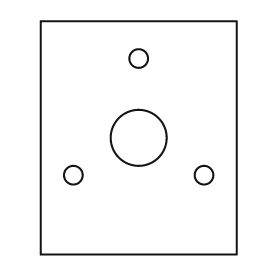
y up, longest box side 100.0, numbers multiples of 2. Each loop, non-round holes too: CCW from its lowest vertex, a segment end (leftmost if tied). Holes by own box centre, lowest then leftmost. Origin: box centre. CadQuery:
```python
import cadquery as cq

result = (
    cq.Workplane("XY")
    .moveTo(-42.0, -50.0)
    .lineTo(42.0, -50.0)
    .lineTo(42.0, 50.0)
    .lineTo(-42.0, 50.0)
    .close()
    .moveTo(-28.0, -16.0)
    .circle(4.0)
    .moveTo(28.0, -16.0)
    .circle(4.0)
    .moveTo(0.0, 0.0)
    .circle(12.0)
    .moveTo(0.0, 34.0)
    .circle(4.0)
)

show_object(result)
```